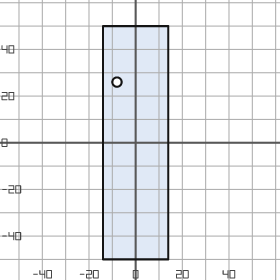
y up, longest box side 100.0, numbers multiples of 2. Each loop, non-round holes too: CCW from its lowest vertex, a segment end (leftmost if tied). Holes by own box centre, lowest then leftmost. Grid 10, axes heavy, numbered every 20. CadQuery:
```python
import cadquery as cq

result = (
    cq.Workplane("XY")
    .moveTo(-14.0, -50.0)
    .lineTo(14.0, -50.0)
    .lineTo(14.0, 50.0)
    .lineTo(-14.0, 50.0)
    .close()
    .moveTo(-8.0, 26.0)
    .circle(2.0)
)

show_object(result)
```